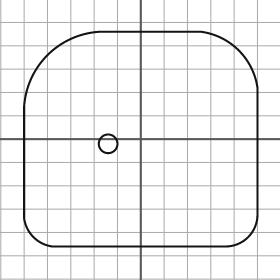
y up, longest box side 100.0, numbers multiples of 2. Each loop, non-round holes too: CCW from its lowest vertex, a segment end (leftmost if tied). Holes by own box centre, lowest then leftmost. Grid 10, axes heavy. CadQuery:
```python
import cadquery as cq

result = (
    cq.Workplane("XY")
    .moveTo(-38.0, -46.0)
    .lineTo(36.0, -46.0)
    .threePointArc((46.0, -42.0), (50.0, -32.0))
    .lineTo(50.0, 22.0)
    .threePointArc((42.0, 38.0), (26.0, 46.0))
    .lineTo(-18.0, 46.0)
    .threePointArc((-40.0, 36.0), (-50.0, 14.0))
    .lineTo(-50.0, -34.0)
    .threePointArc((-46.0, -42.0), (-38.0, -46.0))
    .close()
    .moveTo(-14.0, -2.0)
    .circle(4.0)
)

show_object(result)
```